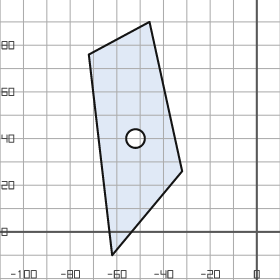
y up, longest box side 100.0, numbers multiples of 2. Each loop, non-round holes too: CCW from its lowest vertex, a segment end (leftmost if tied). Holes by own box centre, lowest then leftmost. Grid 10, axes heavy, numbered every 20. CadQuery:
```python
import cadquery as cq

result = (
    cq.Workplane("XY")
    .moveTo(-62.0, -10.0)
    .lineTo(-32.0, 26.0)
    .lineTo(-46.0, 90.0)
    .lineTo(-72.0, 76.0)
    .close()
    .moveTo(-52.0, 40.0)
    .circle(4.0)
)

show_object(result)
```